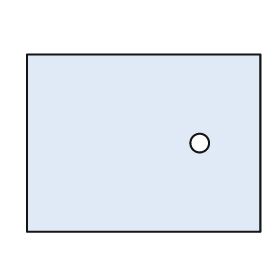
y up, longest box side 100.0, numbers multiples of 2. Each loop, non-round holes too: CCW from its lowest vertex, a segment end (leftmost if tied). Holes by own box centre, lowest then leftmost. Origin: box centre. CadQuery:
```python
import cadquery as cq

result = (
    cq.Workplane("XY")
    .moveTo(-50.0, -38.0)
    .lineTo(50.0, -38.0)
    .lineTo(50.0, 38.0)
    .lineTo(-50.0, 38.0)
    .close()
    .moveTo(24.0, 0.0)
    .circle(4.0)
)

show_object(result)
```